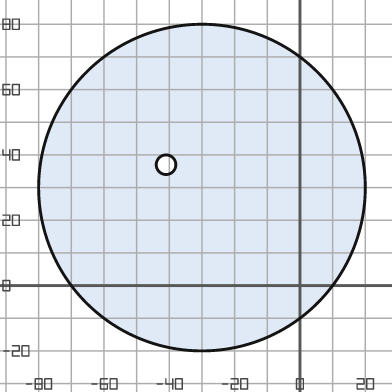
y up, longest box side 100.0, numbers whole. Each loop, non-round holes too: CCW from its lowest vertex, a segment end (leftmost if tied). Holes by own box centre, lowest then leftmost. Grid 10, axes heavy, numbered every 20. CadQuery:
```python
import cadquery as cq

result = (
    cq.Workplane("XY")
    .moveTo(-30.0, 30.0)
    .circle(50.0)
    .moveTo(-41.0, 37.0)
    .circle(3.0)
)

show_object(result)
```